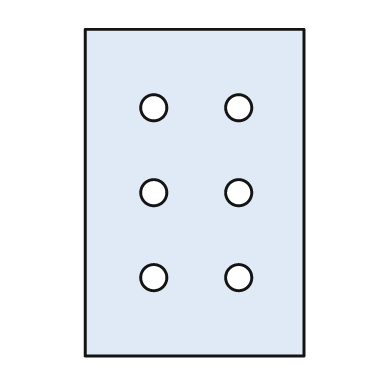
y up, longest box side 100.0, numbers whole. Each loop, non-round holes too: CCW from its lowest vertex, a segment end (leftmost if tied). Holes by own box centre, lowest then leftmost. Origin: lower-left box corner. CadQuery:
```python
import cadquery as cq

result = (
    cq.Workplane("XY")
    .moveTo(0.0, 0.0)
    .lineTo(67.0, 0.0)
    .lineTo(67.0, 100.0)
    .lineTo(0.0, 100.0)
    .close()
    .moveTo(21.0, 24.0)
    .circle(4.0)
    .moveTo(47.0, 24.0)
    .circle(4.0)
    .moveTo(21.0, 50.0)
    .circle(4.0)
    .moveTo(47.0, 50.0)
    .circle(4.0)
    .moveTo(21.0, 76.0)
    .circle(4.0)
    .moveTo(47.0, 76.0)
    .circle(4.0)
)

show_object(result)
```